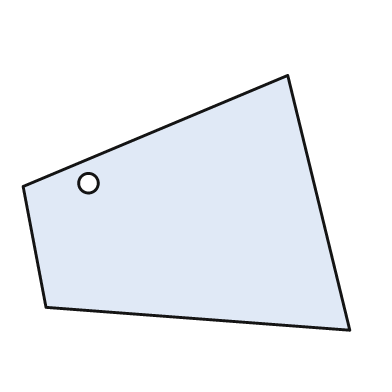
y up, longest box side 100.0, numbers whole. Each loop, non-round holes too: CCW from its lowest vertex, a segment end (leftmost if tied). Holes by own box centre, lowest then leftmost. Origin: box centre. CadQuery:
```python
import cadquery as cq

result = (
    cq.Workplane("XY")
    .moveTo(50.0, -39.0)
    .lineTo(31.0, 39.0)
    .lineTo(-50.0, 5.0)
    .lineTo(-43.0, -32.0)
    .close()
    .moveTo(-30.0, 6.0)
    .circle(3.0)
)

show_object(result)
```